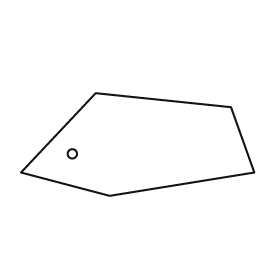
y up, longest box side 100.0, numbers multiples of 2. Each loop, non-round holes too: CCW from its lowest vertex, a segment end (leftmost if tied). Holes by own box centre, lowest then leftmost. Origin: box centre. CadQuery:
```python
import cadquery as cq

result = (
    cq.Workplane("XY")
    .moveTo(-12.0, -22.0)
    .lineTo(50.0, -12.0)
    .lineTo(40.0, 16.0)
    .lineTo(-18.0, 22.0)
    .lineTo(-50.0, -12.0)
    .close()
    .moveTo(-28.0, -4.0)
    .circle(2.0)
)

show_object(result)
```